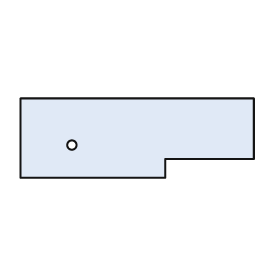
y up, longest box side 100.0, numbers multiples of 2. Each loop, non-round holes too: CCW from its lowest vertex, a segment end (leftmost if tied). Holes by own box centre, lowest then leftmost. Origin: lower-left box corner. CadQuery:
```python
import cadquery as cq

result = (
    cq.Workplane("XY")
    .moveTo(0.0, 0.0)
    .lineTo(62.0, 0.0)
    .lineTo(62.0, 8.0)
    .lineTo(100.0, 8.0)
    .lineTo(100.0, 34.0)
    .lineTo(0.0, 34.0)
    .close()
    .moveTo(22.0, 14.0)
    .circle(2.0)
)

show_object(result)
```